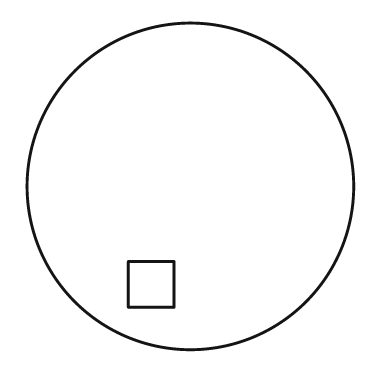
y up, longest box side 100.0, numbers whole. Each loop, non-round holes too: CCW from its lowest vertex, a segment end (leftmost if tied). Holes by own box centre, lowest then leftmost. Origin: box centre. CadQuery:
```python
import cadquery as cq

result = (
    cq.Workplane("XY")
    .moveTo(0.0, 0.0)
    .circle(50.0)
    .moveTo(-19.0, -37.0)
    .lineTo(-5.0, -37.0)
    .lineTo(-5.0, -23.0)
    .lineTo(-19.0, -23.0)
    .close()
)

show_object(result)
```